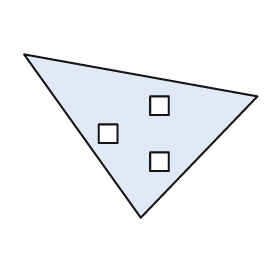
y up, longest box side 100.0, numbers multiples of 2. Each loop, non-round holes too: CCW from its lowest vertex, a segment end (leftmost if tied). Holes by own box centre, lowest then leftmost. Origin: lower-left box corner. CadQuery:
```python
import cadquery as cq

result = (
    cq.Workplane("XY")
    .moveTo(50.0, 0.0)
    .lineTo(100.0, 52.0)
    .lineTo(0.0, 70.0)
    .close()
    .moveTo(54.0, 20.0)
    .lineTo(62.0, 20.0)
    .lineTo(62.0, 28.0)
    .lineTo(54.0, 28.0)
    .close()
    .moveTo(32.0, 32.0)
    .lineTo(40.0, 32.0)
    .lineTo(40.0, 40.0)
    .lineTo(32.0, 40.0)
    .close()
    .moveTo(54.0, 44.0)
    .lineTo(62.0, 44.0)
    .lineTo(62.0, 52.0)
    .lineTo(54.0, 52.0)
    .close()
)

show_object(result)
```